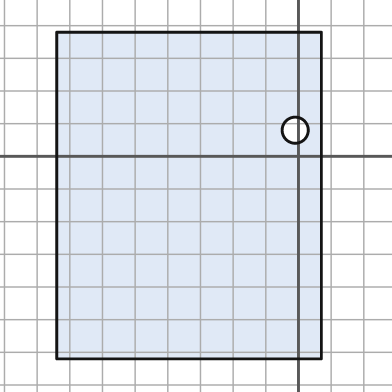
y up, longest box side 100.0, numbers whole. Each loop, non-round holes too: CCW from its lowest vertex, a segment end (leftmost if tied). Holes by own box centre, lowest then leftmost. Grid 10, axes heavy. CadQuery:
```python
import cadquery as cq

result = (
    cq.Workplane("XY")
    .moveTo(-74.0, -62.0)
    .lineTo(7.0, -62.0)
    .lineTo(7.0, 38.0)
    .lineTo(-74.0, 38.0)
    .close()
    .moveTo(-1.0, 8.0)
    .circle(4.0)
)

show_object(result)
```